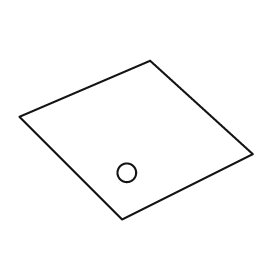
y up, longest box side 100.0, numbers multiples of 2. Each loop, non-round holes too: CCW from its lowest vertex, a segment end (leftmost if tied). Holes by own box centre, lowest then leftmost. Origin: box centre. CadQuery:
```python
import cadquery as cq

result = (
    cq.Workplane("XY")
    .moveTo(-6.0, -34.0)
    .lineTo(50.0, -6.0)
    .lineTo(6.0, 34.0)
    .lineTo(-50.0, 10.0)
    .close()
    .moveTo(-4.0, -14.0)
    .circle(4.0)
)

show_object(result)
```